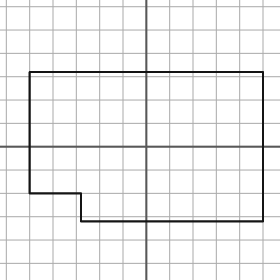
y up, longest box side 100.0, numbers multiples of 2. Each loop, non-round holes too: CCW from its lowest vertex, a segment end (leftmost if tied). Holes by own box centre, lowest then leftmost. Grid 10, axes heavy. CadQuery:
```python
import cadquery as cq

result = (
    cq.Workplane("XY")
    .moveTo(-28.0, -32.0)
    .lineTo(50.0, -32.0)
    .lineTo(50.0, 32.0)
    .lineTo(-50.0, 32.0)
    .lineTo(-50.0, -20.0)
    .lineTo(-28.0, -20.0)
    .close()
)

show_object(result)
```